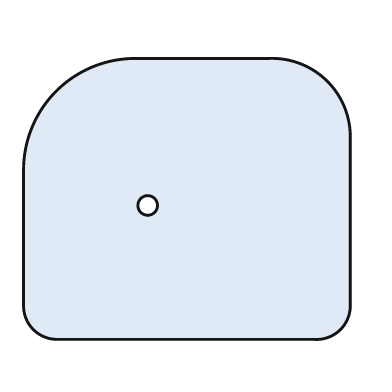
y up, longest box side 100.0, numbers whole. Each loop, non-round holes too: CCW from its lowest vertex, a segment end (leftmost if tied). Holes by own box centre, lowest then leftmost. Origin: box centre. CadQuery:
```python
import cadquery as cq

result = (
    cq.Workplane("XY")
    .moveTo(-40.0, -43.0)
    .lineTo(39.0, -43.0)
    .threePointArc((47.0, -40.0), (50.0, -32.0))
    .lineTo(50.0, 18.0)
    .threePointArc((43.0, 36.0), (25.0, 43.0))
    .lineTo(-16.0, 43.0)
    .threePointArc((-40.0, 33.0), (-50.0, 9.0))
    .lineTo(-50.0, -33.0)
    .threePointArc((-47.0, -40.0), (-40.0, -43.0))
    .close()
    .moveTo(-12.0, -2.0)
    .circle(3.0)
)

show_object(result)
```